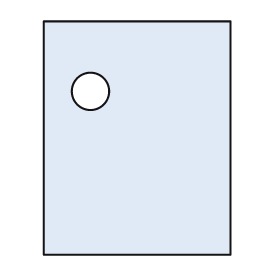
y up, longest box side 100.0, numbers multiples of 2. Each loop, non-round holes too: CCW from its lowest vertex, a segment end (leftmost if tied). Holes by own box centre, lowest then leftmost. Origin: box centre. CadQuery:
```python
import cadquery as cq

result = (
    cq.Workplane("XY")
    .moveTo(-40.0, -50.0)
    .lineTo(40.0, -50.0)
    .lineTo(40.0, 50.0)
    .lineTo(-40.0, 50.0)
    .close()
    .moveTo(-20.0, 20.0)
    .circle(8.0)
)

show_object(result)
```